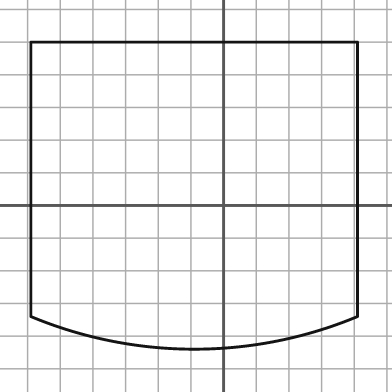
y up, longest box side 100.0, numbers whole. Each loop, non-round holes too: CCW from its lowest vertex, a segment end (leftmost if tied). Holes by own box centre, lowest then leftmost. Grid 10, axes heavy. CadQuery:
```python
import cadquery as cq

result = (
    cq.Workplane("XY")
    .moveTo(-59.0, -34.0)
    .threePointArc((-9.0, -44.0), (41.0, -34.0))
    .lineTo(41.0, 50.0)
    .lineTo(-59.0, 50.0)
    .close()
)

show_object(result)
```